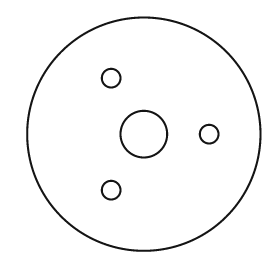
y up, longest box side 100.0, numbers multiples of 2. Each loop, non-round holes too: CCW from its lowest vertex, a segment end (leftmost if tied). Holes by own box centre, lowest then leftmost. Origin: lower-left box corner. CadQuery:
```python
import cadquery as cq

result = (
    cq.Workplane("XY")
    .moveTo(50.0, 50.0)
    .circle(50.0)
    .moveTo(36.0, 26.0)
    .circle(4.0)
    .moveTo(50.0, 50.0)
    .circle(10.0)
    .moveTo(78.0, 50.0)
    .circle(4.0)
    .moveTo(36.0, 74.0)
    .circle(4.0)
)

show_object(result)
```